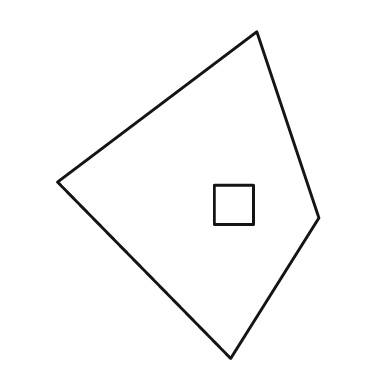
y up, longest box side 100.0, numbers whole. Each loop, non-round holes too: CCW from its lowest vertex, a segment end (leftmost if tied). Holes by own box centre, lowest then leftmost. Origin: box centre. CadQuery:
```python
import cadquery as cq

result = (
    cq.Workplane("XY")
    .moveTo(13.0, -50.0)
    .lineTo(40.0, -7.0)
    .lineTo(21.0, 50.0)
    .lineTo(-40.0, 4.0)
    .close()
    .moveTo(8.0, -9.0)
    .lineTo(20.0, -9.0)
    .lineTo(20.0, 3.0)
    .lineTo(8.0, 3.0)
    .close()
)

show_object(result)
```